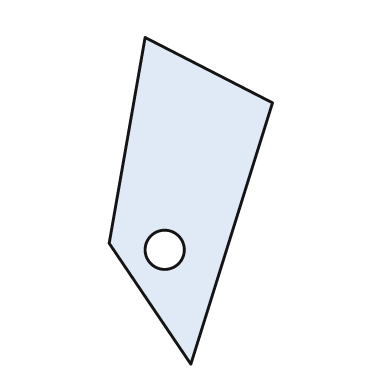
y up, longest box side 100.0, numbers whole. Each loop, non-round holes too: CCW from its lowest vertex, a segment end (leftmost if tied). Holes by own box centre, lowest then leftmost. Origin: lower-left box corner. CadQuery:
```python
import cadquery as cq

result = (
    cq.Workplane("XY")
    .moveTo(25.0, 0.0)
    .lineTo(50.0, 80.0)
    .lineTo(11.0, 100.0)
    .lineTo(0.0, 37.0)
    .close()
    .moveTo(17.0, 35.0)
    .circle(6.0)
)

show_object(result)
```